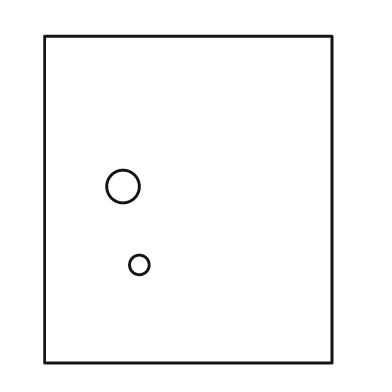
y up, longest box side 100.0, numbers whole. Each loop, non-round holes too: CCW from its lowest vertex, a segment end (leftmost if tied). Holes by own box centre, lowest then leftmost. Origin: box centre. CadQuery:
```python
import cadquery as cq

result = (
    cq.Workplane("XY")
    .moveTo(-44.0, -50.0)
    .lineTo(44.0, -50.0)
    .lineTo(44.0, 50.0)
    .lineTo(-44.0, 50.0)
    .close()
    .moveTo(-15.0, -20.0)
    .circle(3.0)
    .moveTo(-20.0, 4.0)
    .circle(5.0)
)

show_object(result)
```